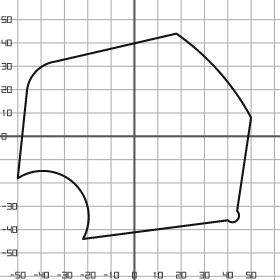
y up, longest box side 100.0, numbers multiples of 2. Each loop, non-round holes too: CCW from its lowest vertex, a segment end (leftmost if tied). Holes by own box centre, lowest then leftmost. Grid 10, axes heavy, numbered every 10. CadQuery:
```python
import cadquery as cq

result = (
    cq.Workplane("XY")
    .moveTo(-22.0, -44.0)
    .lineTo(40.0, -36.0)
    .threePointArc((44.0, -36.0), (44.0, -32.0))
    .lineTo(50.0, 8.0)
    .threePointArc((36.0, 28.0), (18.0, 44.0))
    .lineTo(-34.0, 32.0)
    .threePointArc((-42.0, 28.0), (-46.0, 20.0))
    .lineTo(-50.0, -18.0)
    .threePointArc((-26.0, -20.0), (-22.0, -44.0))
    .close()
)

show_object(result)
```